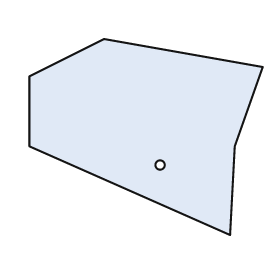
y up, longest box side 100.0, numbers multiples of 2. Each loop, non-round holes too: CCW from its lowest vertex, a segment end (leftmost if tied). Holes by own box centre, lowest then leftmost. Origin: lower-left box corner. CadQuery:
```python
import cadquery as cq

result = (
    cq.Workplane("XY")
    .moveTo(86.0, 0.0)
    .lineTo(88.0, 38.0)
    .lineTo(100.0, 72.0)
    .lineTo(32.0, 84.0)
    .lineTo(0.0, 68.0)
    .lineTo(0.0, 38.0)
    .close()
    .moveTo(56.0, 30.0)
    .circle(2.0)
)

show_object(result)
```